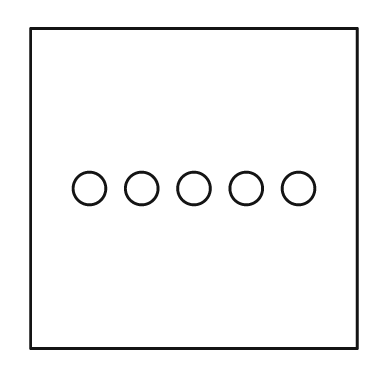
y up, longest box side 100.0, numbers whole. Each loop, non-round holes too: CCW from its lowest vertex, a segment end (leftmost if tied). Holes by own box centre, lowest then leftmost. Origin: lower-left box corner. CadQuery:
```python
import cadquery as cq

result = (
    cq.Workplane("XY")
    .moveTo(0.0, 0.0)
    .lineTo(100.0, 0.0)
    .lineTo(100.0, 98.0)
    .lineTo(0.0, 98.0)
    .close()
    .moveTo(18.0, 49.0)
    .circle(5.0)
    .moveTo(34.0, 49.0)
    .circle(5.0)
    .moveTo(50.0, 49.0)
    .circle(5.0)
    .moveTo(66.0, 49.0)
    .circle(5.0)
    .moveTo(82.0, 49.0)
    .circle(5.0)
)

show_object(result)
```